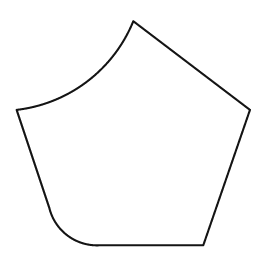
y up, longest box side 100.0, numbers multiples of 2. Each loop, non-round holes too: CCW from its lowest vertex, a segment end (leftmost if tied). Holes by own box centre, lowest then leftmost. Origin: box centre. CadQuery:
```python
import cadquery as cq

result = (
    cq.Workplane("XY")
    .moveTo(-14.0, -48.0)
    .lineTo(30.0, -48.0)
    .lineTo(50.0, 10.0)
    .lineTo(0.0, 48.0)
    .threePointArc((-20.0, 22.0), (-50.0, 10.0))
    .lineTo(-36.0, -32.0)
    .threePointArc((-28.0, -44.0), (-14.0, -48.0))
    .close()
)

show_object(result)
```